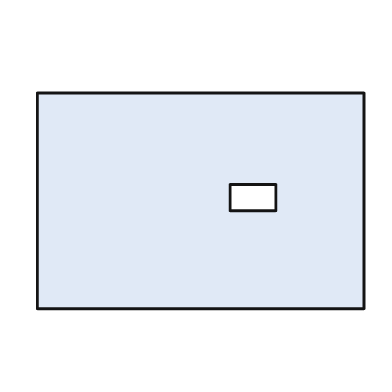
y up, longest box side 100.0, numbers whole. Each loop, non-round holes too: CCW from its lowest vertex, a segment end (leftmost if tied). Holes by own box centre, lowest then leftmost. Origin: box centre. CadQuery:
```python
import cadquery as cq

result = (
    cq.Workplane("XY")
    .moveTo(-50.0, -33.0)
    .lineTo(50.0, -33.0)
    .lineTo(50.0, 33.0)
    .lineTo(-50.0, 33.0)
    .close()
    .moveTo(9.0, -3.0)
    .lineTo(23.0, -3.0)
    .lineTo(23.0, 5.0)
    .lineTo(9.0, 5.0)
    .close()
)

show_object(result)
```